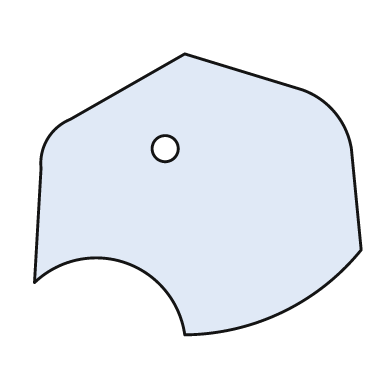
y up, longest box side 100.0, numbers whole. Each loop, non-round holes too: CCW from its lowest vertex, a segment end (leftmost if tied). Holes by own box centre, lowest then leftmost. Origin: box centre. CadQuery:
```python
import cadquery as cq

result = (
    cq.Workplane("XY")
    .moveTo(-4.0, -43.0)
    .threePointArc((26.0, -36.0), (50.0, -17.0))
    .lineTo(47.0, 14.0)
    .threePointArc((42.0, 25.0), (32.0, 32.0))
    .lineTo(-4.0, 43.0)
    .lineTo(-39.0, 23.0)
    .threePointArc((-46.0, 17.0), (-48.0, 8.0))
    .lineTo(-50.0, -27.0)
    .threePointArc((-22.0, -21.0), (-4.0, -43.0))
    .close()
    .moveTo(-10.0, 14.0)
    .circle(4.0)
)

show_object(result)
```